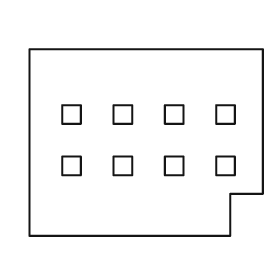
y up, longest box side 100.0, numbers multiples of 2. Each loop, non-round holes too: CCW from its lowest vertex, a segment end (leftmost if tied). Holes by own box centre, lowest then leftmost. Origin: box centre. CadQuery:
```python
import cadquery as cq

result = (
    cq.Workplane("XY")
    .moveTo(-50.0, -40.0)
    .lineTo(36.0, -40.0)
    .lineTo(36.0, -22.0)
    .lineTo(50.0, -22.0)
    .lineTo(50.0, 40.0)
    .lineTo(-50.0, 40.0)
    .close()
    .moveTo(-36.0, -14.0)
    .lineTo(-28.0, -14.0)
    .lineTo(-28.0, -6.0)
    .lineTo(-36.0, -6.0)
    .close()
    .moveTo(-14.0, -14.0)
    .lineTo(-6.0, -14.0)
    .lineTo(-6.0, -6.0)
    .lineTo(-14.0, -6.0)
    .close()
    .moveTo(8.0, -14.0)
    .lineTo(16.0, -14.0)
    .lineTo(16.0, -6.0)
    .lineTo(8.0, -6.0)
    .close()
    .moveTo(30.0, -14.0)
    .lineTo(38.0, -14.0)
    .lineTo(38.0, -6.0)
    .lineTo(30.0, -6.0)
    .close()
    .moveTo(-36.0, 8.0)
    .lineTo(-28.0, 8.0)
    .lineTo(-28.0, 16.0)
    .lineTo(-36.0, 16.0)
    .close()
    .moveTo(-14.0, 8.0)
    .lineTo(-6.0, 8.0)
    .lineTo(-6.0, 16.0)
    .lineTo(-14.0, 16.0)
    .close()
    .moveTo(8.0, 8.0)
    .lineTo(16.0, 8.0)
    .lineTo(16.0, 16.0)
    .lineTo(8.0, 16.0)
    .close()
    .moveTo(30.0, 8.0)
    .lineTo(38.0, 8.0)
    .lineTo(38.0, 16.0)
    .lineTo(30.0, 16.0)
    .close()
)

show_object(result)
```